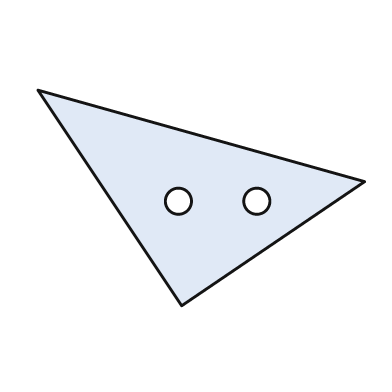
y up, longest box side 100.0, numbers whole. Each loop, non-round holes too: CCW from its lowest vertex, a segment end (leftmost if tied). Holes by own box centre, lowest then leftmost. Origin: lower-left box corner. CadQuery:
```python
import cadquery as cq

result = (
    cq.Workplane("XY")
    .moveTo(44.0, 0.0)
    .lineTo(100.0, 38.0)
    .lineTo(0.0, 66.0)
    .close()
    .moveTo(43.0, 32.0)
    .circle(4.0)
    .moveTo(67.0, 32.0)
    .circle(4.0)
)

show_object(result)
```